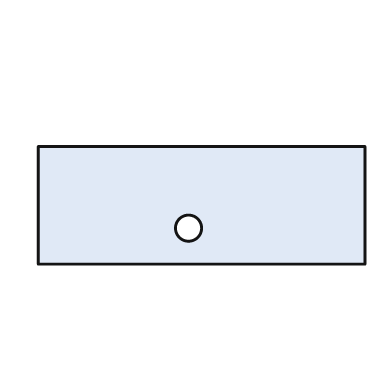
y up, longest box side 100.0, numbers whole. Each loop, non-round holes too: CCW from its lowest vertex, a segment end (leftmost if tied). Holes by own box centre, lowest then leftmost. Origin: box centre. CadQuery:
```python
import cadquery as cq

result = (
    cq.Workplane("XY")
    .moveTo(-50.0, -18.0)
    .lineTo(50.0, -18.0)
    .lineTo(50.0, 18.0)
    .lineTo(-50.0, 18.0)
    .close()
    .moveTo(-4.0, -7.0)
    .circle(4.0)
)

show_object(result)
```